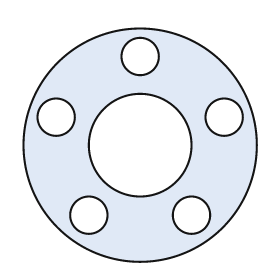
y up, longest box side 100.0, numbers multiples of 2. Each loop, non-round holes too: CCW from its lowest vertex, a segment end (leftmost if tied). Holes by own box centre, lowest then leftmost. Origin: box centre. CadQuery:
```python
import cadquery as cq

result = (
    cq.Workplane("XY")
    .moveTo(0.0, 0.0)
    .circle(50.0)
    .moveTo(-22.0, -30.0)
    .circle(8.0)
    .moveTo(22.0, -30.0)
    .circle(8.0)
    .moveTo(0.0, 0.0)
    .circle(22.0)
    .moveTo(-36.0, 12.0)
    .circle(8.0)
    .moveTo(36.0, 12.0)
    .circle(8.0)
    .moveTo(0.0, 38.0)
    .circle(8.0)
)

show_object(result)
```